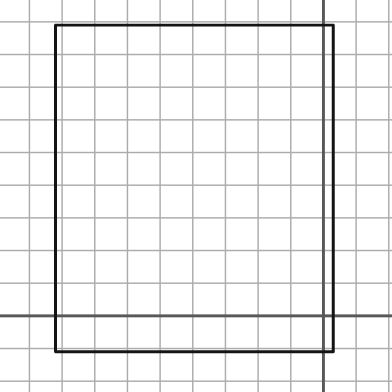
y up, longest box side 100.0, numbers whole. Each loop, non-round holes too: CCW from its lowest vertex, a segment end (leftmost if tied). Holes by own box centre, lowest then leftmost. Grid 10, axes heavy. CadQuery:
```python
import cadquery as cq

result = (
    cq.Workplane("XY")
    .moveTo(-82.0, -11.0)
    .lineTo(3.0, -11.0)
    .lineTo(3.0, 89.0)
    .lineTo(-82.0, 89.0)
    .close()
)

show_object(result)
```